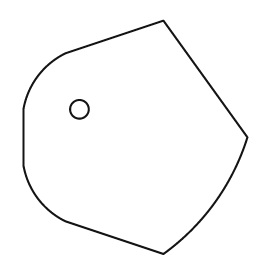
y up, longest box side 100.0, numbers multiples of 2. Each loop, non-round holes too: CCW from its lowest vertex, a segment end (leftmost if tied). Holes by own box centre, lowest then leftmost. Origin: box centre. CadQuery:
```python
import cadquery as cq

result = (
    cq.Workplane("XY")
    .moveTo(12.0, -50.0)
    .threePointArc((34.0, -28.0), (48.0, 0.0))
    .lineTo(12.0, 50.0)
    .lineTo(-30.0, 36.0)
    .threePointArc((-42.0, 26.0), (-48.0, 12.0))
    .lineTo(-48.0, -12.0)
    .threePointArc((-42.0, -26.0), (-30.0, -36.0))
    .close()
    .moveTo(-24.0, 12.0)
    .circle(4.0)
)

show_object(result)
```